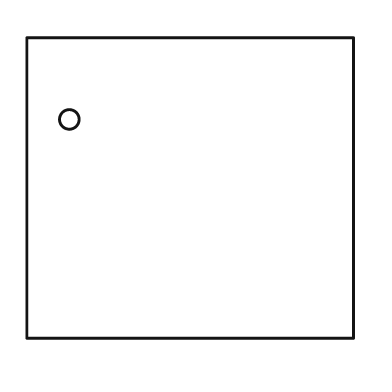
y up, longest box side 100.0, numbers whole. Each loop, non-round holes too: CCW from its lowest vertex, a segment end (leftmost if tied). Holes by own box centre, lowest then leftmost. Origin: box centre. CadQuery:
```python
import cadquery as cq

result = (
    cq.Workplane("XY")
    .moveTo(-50.0, -46.0)
    .lineTo(50.0, -46.0)
    .lineTo(50.0, 46.0)
    .lineTo(-50.0, 46.0)
    .close()
    .moveTo(-37.0, 21.0)
    .circle(3.0)
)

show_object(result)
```